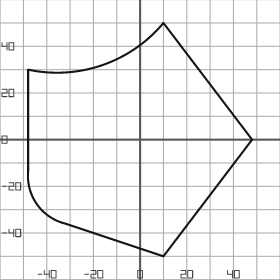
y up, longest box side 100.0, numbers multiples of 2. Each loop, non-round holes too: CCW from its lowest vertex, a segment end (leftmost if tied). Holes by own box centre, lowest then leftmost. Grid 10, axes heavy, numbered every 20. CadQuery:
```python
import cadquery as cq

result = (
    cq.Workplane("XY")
    .moveTo(10.0, -50.0)
    .lineTo(48.0, 0.0)
    .lineTo(10.0, 50.0)
    .threePointArc((-16.0, 32.0), (-48.0, 30.0))
    .lineTo(-48.0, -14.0)
    .threePointArc((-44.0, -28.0), (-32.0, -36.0))
    .close()
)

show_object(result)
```